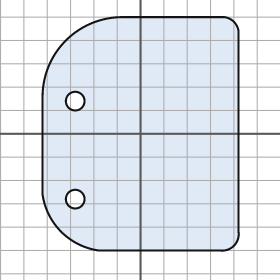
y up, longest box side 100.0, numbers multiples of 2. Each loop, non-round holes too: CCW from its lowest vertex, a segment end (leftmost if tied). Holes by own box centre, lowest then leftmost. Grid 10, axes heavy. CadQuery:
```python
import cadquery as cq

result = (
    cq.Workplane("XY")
    .moveTo(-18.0, -50.0)
    .lineTo(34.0, -50.0)
    .threePointArc((40.0, -48.0), (42.0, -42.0))
    .lineTo(42.0, 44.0)
    .threePointArc((40.0, 48.0), (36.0, 50.0))
    .lineTo(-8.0, 50.0)
    .threePointArc((-32.0, 40.0), (-42.0, 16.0))
    .lineTo(-42.0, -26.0)
    .threePointArc((-34.0, -42.0), (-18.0, -50.0))
    .close()
    .moveTo(-28.0, -28.0)
    .circle(4.0)
    .moveTo(-28.0, 14.0)
    .circle(4.0)
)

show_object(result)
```